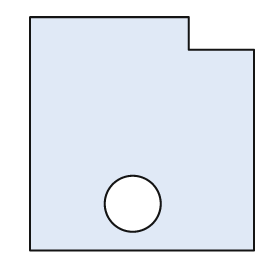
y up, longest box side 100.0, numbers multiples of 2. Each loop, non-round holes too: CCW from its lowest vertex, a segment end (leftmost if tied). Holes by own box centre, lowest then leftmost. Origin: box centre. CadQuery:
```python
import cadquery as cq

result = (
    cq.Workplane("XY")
    .moveTo(-48.0, -50.0)
    .lineTo(48.0, -50.0)
    .lineTo(48.0, 36.0)
    .lineTo(20.0, 36.0)
    .lineTo(20.0, 50.0)
    .lineTo(-48.0, 50.0)
    .close()
    .moveTo(-4.0, -30.0)
    .circle(12.0)
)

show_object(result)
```